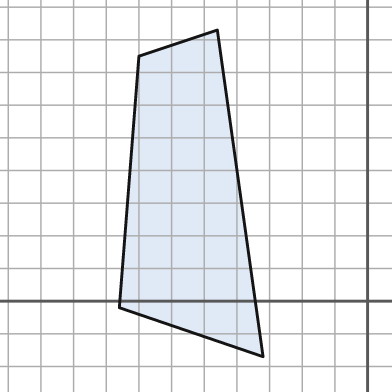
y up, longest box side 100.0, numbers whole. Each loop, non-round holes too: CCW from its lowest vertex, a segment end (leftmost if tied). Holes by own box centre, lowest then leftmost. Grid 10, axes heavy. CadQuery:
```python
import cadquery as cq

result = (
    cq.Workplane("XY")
    .moveTo(-32.0, -17.0)
    .lineTo(-46.0, 83.0)
    .lineTo(-70.0, 75.0)
    .lineTo(-76.0, -2.0)
    .close()
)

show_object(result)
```